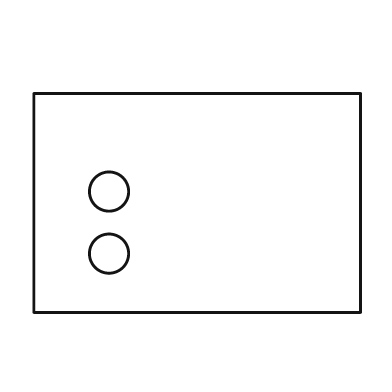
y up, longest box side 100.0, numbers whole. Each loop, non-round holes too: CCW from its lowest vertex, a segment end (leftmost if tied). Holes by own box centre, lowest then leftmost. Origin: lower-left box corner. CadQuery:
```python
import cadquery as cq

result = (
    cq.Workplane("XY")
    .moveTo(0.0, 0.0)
    .lineTo(100.0, 0.0)
    .lineTo(100.0, 67.0)
    .lineTo(0.0, 67.0)
    .close()
    .moveTo(23.0, 18.0)
    .circle(6.0)
    .moveTo(23.0, 37.0)
    .circle(6.0)
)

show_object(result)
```